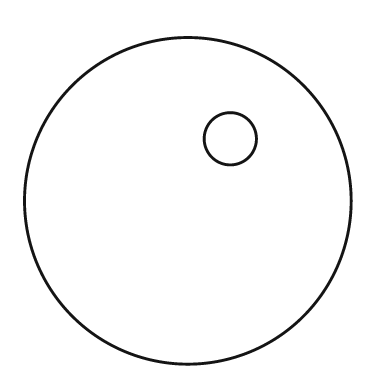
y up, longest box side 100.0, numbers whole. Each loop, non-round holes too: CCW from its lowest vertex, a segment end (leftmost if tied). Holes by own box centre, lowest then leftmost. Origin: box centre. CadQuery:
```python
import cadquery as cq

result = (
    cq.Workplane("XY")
    .moveTo(0.0, 0.0)
    .circle(50.0)
    .moveTo(13.0, 19.0)
    .circle(8.0)
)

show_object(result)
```